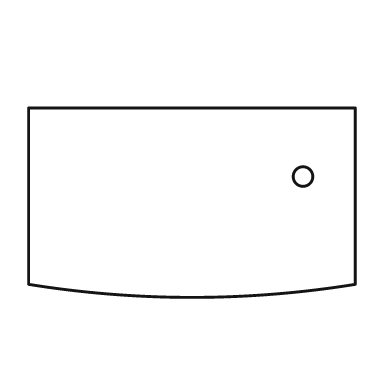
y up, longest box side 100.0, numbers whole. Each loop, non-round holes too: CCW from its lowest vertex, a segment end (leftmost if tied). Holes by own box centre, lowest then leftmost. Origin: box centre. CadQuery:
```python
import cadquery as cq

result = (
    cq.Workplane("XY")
    .moveTo(-50.0, -25.0)
    .threePointArc((0.0, -29.0), (50.0, -25.0))
    .lineTo(50.0, 29.0)
    .lineTo(-50.0, 29.0)
    .close()
    .moveTo(34.0, 8.0)
    .circle(3.0)
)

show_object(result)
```